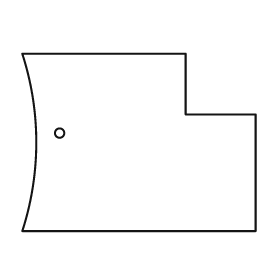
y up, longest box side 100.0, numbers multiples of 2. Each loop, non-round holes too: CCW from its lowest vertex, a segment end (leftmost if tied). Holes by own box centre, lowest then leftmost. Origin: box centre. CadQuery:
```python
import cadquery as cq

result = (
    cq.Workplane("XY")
    .moveTo(-50.0, -38.0)
    .lineTo(50.0, -38.0)
    .lineTo(50.0, 12.0)
    .lineTo(20.0, 12.0)
    .lineTo(20.0, 38.0)
    .lineTo(-50.0, 38.0)
    .threePointArc((-44.0, 0.0), (-50.0, -38.0))
    .close()
    .moveTo(-34.0, 4.0)
    .circle(2.0)
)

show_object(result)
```